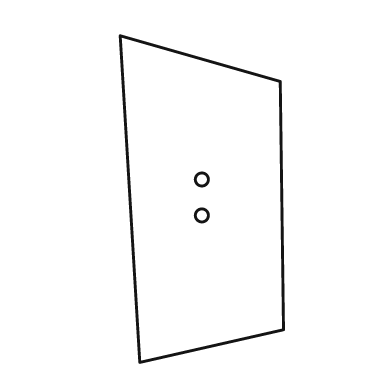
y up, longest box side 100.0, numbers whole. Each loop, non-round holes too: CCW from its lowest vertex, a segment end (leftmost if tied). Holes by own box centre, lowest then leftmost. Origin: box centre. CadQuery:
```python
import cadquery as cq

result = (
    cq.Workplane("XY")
    .moveTo(-19.0, -50.0)
    .lineTo(25.0, -40.0)
    .lineTo(24.0, 36.0)
    .lineTo(-25.0, 50.0)
    .close()
    .moveTo(0.0, -5.0)
    .circle(2.0)
    .moveTo(0.0, 6.0)
    .circle(2.0)
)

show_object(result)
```